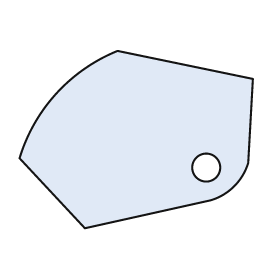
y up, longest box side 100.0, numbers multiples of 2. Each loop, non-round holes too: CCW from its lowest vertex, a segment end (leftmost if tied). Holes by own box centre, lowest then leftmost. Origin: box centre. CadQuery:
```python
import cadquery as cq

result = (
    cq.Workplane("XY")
    .moveTo(-22.0, -38.0)
    .lineTo(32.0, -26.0)
    .threePointArc((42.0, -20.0), (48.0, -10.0))
    .lineTo(50.0, 26.0)
    .lineTo(-8.0, 38.0)
    .threePointArc((-34.0, 20.0), (-50.0, -8.0))
    .close()
    .moveTo(30.0, -12.0)
    .circle(6.0)
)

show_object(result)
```